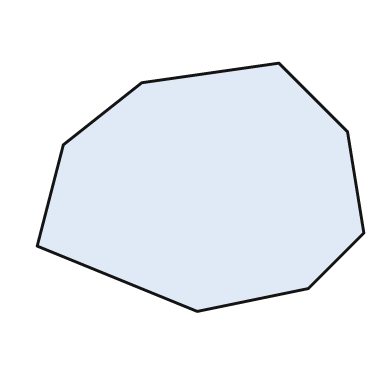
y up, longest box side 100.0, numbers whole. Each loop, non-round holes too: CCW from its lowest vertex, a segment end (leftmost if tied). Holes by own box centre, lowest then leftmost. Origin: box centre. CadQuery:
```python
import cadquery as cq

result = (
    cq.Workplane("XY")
    .moveTo(-1.0, -38.0)
    .lineTo(33.0, -31.0)
    .lineTo(50.0, -14.0)
    .lineTo(45.0, 17.0)
    .lineTo(24.0, 38.0)
    .lineTo(-18.0, 32.0)
    .lineTo(-42.0, 13.0)
    .lineTo(-50.0, -18.0)
    .close()
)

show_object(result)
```